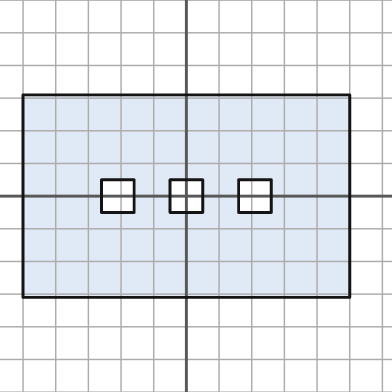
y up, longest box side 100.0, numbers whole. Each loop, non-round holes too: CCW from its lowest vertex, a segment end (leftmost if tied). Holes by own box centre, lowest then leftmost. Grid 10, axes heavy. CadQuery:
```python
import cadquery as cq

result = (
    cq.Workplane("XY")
    .moveTo(-50.0, -31.0)
    .lineTo(50.0, -31.0)
    .lineTo(50.0, 31.0)
    .lineTo(-50.0, 31.0)
    .close()
    .moveTo(-26.0, -5.0)
    .lineTo(-16.0, -5.0)
    .lineTo(-16.0, 5.0)
    .lineTo(-26.0, 5.0)
    .close()
    .moveTo(-5.0, -5.0)
    .lineTo(5.0, -5.0)
    .lineTo(5.0, 5.0)
    .lineTo(-5.0, 5.0)
    .close()
    .moveTo(16.0, -5.0)
    .lineTo(26.0, -5.0)
    .lineTo(26.0, 5.0)
    .lineTo(16.0, 5.0)
    .close()
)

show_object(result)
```